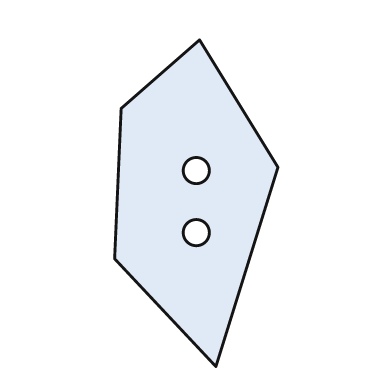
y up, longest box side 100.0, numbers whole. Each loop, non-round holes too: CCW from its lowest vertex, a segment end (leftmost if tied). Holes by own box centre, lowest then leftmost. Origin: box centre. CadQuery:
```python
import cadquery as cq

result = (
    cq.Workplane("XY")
    .moveTo(6.0, -50.0)
    .lineTo(25.0, 11.0)
    .lineTo(1.0, 50.0)
    .lineTo(-23.0, 29.0)
    .lineTo(-25.0, -17.0)
    .close()
    .moveTo(0.0, -9.0)
    .circle(4.0)
    .moveTo(0.0, 10.0)
    .circle(4.0)
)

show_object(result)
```